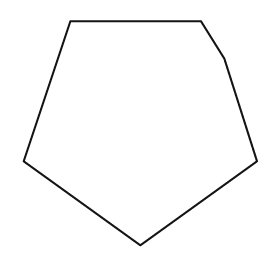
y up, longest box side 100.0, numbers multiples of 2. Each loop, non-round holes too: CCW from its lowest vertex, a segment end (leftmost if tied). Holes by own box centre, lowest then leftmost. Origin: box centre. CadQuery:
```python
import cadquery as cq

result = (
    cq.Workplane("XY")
    .moveTo(0.0, -48.0)
    .lineTo(50.0, -12.0)
    .lineTo(36.0, 32.0)
    .lineTo(26.0, 48.0)
    .lineTo(-30.0, 48.0)
    .lineTo(-50.0, -12.0)
    .close()
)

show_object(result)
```